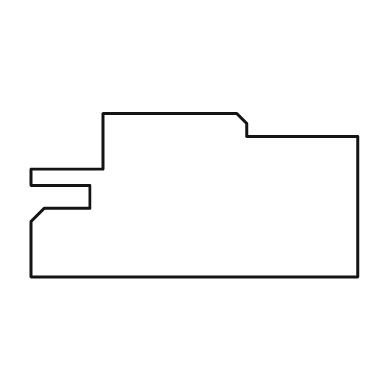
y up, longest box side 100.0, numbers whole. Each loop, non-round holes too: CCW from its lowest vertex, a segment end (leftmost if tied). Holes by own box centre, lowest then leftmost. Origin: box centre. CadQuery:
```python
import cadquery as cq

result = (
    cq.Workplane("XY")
    .moveTo(-50.0, -25.0)
    .lineTo(50.0, -25.0)
    .lineTo(50.0, 18.0)
    .lineTo(16.0, 18.0)
    .lineTo(16.0, 22.0)
    .lineTo(13.0, 25.0)
    .lineTo(-28.0, 25.0)
    .lineTo(-28.0, 8.0)
    .lineTo(-50.0, 8.0)
    .lineTo(-50.0, 3.0)
    .lineTo(-32.0, 3.0)
    .lineTo(-32.0, -4.0)
    .lineTo(-46.0, -4.0)
    .lineTo(-50.0, -8.0)
    .close()
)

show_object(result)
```